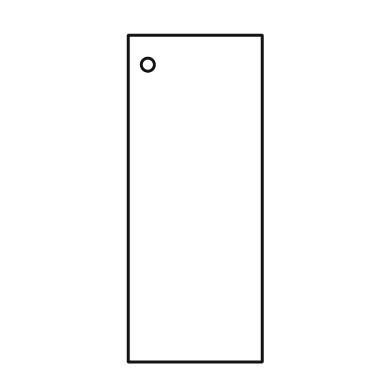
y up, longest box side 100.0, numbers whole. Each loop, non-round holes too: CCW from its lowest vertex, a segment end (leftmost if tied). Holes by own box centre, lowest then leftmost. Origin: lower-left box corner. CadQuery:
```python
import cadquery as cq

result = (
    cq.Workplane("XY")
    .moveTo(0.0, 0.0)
    .lineTo(41.0, 0.0)
    .lineTo(41.0, 100.0)
    .lineTo(0.0, 100.0)
    .close()
    .moveTo(6.0, 91.0)
    .circle(2.0)
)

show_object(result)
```